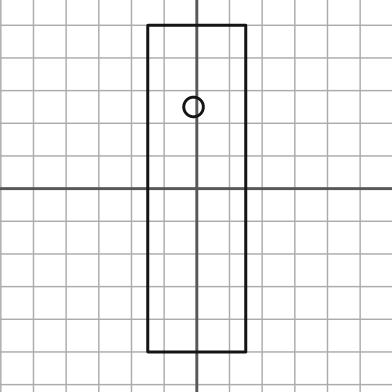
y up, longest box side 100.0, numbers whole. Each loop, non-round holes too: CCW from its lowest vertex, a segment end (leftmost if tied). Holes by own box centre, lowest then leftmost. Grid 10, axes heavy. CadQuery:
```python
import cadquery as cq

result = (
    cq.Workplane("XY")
    .moveTo(-15.0, -50.0)
    .lineTo(15.0, -50.0)
    .lineTo(15.0, 50.0)
    .lineTo(-15.0, 50.0)
    .close()
    .moveTo(-1.0, 25.0)
    .circle(3.0)
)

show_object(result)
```